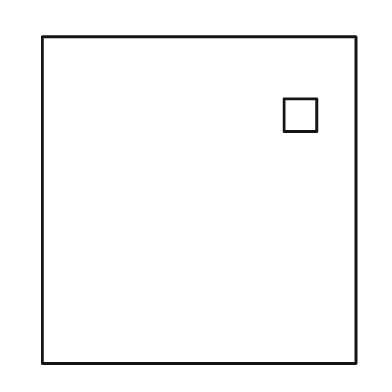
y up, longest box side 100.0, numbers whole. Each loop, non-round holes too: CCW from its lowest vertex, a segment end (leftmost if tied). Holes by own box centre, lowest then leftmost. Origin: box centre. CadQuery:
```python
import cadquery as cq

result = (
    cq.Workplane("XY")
    .moveTo(-48.0, -50.0)
    .lineTo(48.0, -50.0)
    .lineTo(48.0, 50.0)
    .lineTo(-48.0, 50.0)
    .close()
    .moveTo(26.0, 21.0)
    .lineTo(36.0, 21.0)
    .lineTo(36.0, 31.0)
    .lineTo(26.0, 31.0)
    .close()
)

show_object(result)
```